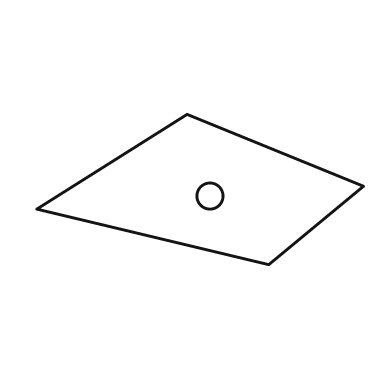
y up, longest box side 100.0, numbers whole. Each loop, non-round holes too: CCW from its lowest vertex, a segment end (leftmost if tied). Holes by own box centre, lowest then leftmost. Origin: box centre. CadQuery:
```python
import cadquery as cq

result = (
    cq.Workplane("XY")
    .moveTo(21.0, -23.0)
    .lineTo(50.0, 1.0)
    .lineTo(-4.0, 23.0)
    .lineTo(-50.0, -6.0)
    .close()
    .moveTo(3.0, -2.0)
    .circle(4.0)
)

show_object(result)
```